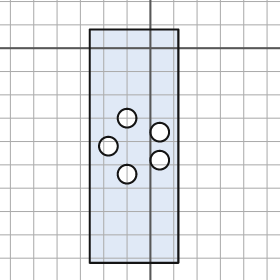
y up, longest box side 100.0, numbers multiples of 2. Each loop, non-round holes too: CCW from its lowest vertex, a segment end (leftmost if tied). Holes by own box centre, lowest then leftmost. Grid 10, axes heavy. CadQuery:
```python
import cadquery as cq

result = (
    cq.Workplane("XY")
    .moveTo(-26.0, -92.0)
    .lineTo(12.0, -92.0)
    .lineTo(12.0, 8.0)
    .lineTo(-26.0, 8.0)
    .close()
    .moveTo(-10.0, -54.0)
    .circle(4.0)
    .moveTo(4.0, -48.0)
    .circle(4.0)
    .moveTo(-18.0, -42.0)
    .circle(4.0)
    .moveTo(4.0, -36.0)
    .circle(4.0)
    .moveTo(-10.0, -30.0)
    .circle(4.0)
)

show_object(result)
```